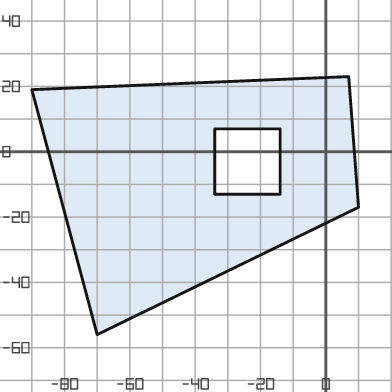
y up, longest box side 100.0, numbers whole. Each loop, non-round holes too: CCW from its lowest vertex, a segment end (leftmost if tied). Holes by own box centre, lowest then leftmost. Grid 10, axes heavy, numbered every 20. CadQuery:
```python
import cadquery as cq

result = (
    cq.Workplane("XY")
    .moveTo(-70.0, -56.0)
    .lineTo(10.0, -17.0)
    .lineTo(7.0, 23.0)
    .lineTo(-90.0, 19.0)
    .close()
    .moveTo(-34.0, -13.0)
    .lineTo(-14.0, -13.0)
    .lineTo(-14.0, 7.0)
    .lineTo(-34.0, 7.0)
    .close()
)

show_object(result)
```